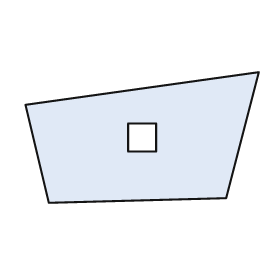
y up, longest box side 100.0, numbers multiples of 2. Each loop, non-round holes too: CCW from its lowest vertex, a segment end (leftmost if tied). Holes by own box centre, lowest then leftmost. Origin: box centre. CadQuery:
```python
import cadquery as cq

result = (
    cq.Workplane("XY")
    .moveTo(-40.0, -28.0)
    .lineTo(36.0, -26.0)
    .lineTo(50.0, 28.0)
    .lineTo(-50.0, 14.0)
    .close()
    .moveTo(-6.0, -6.0)
    .lineTo(6.0, -6.0)
    .lineTo(6.0, 6.0)
    .lineTo(-6.0, 6.0)
    .close()
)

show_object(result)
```